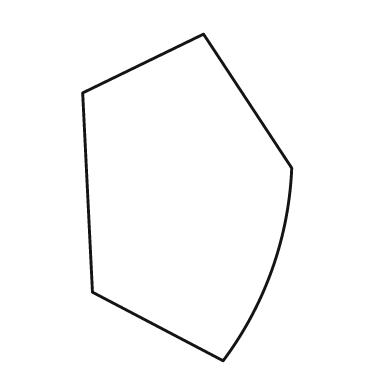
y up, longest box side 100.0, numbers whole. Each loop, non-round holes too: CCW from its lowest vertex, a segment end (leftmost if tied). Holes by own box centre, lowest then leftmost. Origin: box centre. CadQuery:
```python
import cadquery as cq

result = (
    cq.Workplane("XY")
    .moveTo(11.0, -50.0)
    .threePointArc((26.0, -22.0), (32.0, 9.0))
    .lineTo(5.0, 50.0)
    .lineTo(-32.0, 32.0)
    .lineTo(-29.0, -29.0)
    .close()
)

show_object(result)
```